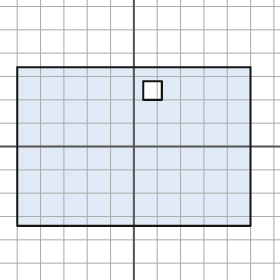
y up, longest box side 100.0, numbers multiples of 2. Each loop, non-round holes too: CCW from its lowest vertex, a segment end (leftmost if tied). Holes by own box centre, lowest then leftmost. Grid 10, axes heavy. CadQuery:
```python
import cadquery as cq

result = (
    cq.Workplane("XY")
    .moveTo(-50.0, -34.0)
    .lineTo(50.0, -34.0)
    .lineTo(50.0, 34.0)
    .lineTo(-50.0, 34.0)
    .close()
    .moveTo(4.0, 20.0)
    .lineTo(12.0, 20.0)
    .lineTo(12.0, 28.0)
    .lineTo(4.0, 28.0)
    .close()
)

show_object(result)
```